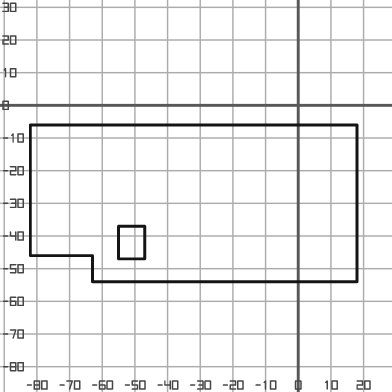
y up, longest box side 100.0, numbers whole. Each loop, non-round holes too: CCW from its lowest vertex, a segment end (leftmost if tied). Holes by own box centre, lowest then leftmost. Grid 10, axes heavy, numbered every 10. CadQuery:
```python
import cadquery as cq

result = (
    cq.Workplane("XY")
    .moveTo(-63.0, -54.0)
    .lineTo(18.0, -54.0)
    .lineTo(18.0, -6.0)
    .lineTo(-82.0, -6.0)
    .lineTo(-82.0, -46.0)
    .lineTo(-63.0, -46.0)
    .close()
    .moveTo(-55.0, -47.0)
    .lineTo(-47.0, -47.0)
    .lineTo(-47.0, -37.0)
    .lineTo(-55.0, -37.0)
    .close()
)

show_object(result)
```